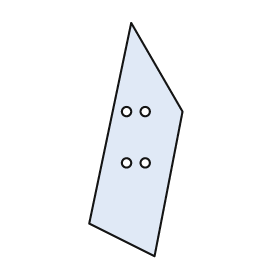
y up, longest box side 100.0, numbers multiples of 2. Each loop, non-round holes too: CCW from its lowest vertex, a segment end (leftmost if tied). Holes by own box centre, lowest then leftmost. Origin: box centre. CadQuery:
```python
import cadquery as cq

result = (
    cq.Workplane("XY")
    .moveTo(8.0, -50.0)
    .lineTo(20.0, 12.0)
    .lineTo(-2.0, 50.0)
    .lineTo(-20.0, -36.0)
    .close()
    .moveTo(-4.0, -10.0)
    .circle(2.0)
    .moveTo(4.0, -10.0)
    .circle(2.0)
    .moveTo(-4.0, 12.0)
    .circle(2.0)
    .moveTo(4.0, 12.0)
    .circle(2.0)
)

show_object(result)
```